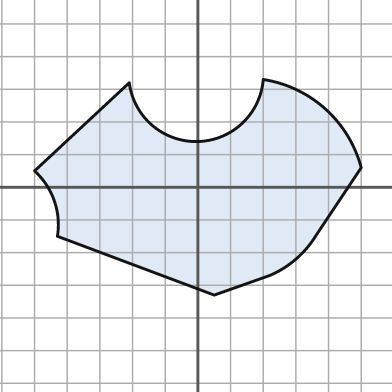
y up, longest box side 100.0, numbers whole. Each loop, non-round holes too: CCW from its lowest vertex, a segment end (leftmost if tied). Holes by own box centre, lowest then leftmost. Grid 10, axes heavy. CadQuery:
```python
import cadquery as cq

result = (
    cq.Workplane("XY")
    .moveTo(5.0, -33.0)
    .lineTo(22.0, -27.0)
    .threePointArc((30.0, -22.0), (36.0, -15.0))
    .lineTo(50.0, 6.0)
    .threePointArc((39.0, 24.0), (20.0, 33.0))
    .threePointArc((0.0, 14.0), (-21.0, 32.0))
    .lineTo(-50.0, 5.0)
    .threePointArc((-44.0, -4.0), (-43.0, -15.0))
    .close()
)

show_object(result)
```